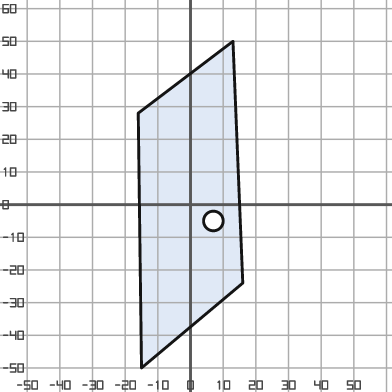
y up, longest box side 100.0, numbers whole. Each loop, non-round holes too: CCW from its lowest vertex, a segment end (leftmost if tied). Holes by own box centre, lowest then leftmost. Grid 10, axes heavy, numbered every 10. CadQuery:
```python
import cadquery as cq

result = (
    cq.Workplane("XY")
    .moveTo(-15.0, -50.0)
    .lineTo(16.0, -24.0)
    .lineTo(13.0, 50.0)
    .lineTo(-16.0, 28.0)
    .close()
    .moveTo(7.0, -5.0)
    .circle(3.0)
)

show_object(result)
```